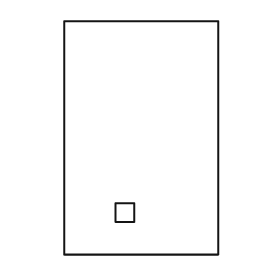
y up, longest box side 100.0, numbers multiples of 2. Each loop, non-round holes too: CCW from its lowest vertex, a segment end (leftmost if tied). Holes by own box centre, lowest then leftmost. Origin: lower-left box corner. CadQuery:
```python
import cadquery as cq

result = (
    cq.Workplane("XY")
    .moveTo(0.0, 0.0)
    .lineTo(66.0, 0.0)
    .lineTo(66.0, 100.0)
    .lineTo(0.0, 100.0)
    .close()
    .moveTo(22.0, 14.0)
    .lineTo(30.0, 14.0)
    .lineTo(30.0, 22.0)
    .lineTo(22.0, 22.0)
    .close()
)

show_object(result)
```